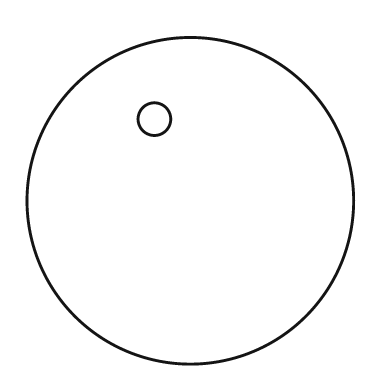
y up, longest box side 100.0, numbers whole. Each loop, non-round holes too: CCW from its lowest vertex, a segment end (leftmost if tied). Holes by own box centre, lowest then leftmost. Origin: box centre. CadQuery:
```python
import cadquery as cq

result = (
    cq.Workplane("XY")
    .moveTo(0.0, 0.0)
    .circle(50.0)
    .moveTo(-11.0, 25.0)
    .circle(5.0)
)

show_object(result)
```